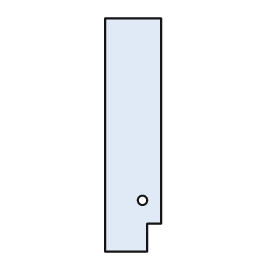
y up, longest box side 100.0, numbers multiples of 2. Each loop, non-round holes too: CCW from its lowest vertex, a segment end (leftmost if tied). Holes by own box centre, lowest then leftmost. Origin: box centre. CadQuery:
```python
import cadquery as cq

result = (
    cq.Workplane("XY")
    .moveTo(-12.0, -50.0)
    .lineTo(6.0, -50.0)
    .lineTo(6.0, -38.0)
    .lineTo(12.0, -38.0)
    .lineTo(12.0, 50.0)
    .lineTo(-12.0, 50.0)
    .close()
    .moveTo(4.0, -28.0)
    .circle(2.0)
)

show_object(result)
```